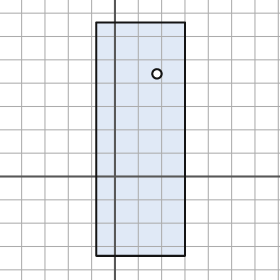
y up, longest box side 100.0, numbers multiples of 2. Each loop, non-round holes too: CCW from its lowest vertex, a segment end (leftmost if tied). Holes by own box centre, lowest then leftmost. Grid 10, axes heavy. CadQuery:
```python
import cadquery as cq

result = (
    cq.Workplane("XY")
    .moveTo(-8.0, -34.0)
    .lineTo(30.0, -34.0)
    .lineTo(30.0, 66.0)
    .lineTo(-8.0, 66.0)
    .close()
    .moveTo(18.0, 44.0)
    .circle(2.0)
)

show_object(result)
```